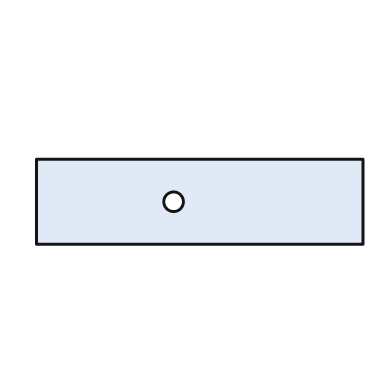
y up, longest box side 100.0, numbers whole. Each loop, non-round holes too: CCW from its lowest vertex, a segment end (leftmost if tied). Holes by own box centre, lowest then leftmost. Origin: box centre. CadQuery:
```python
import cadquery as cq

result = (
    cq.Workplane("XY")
    .moveTo(-50.0, -13.0)
    .lineTo(50.0, -13.0)
    .lineTo(50.0, 13.0)
    .lineTo(-50.0, 13.0)
    .close()
    .moveTo(-8.0, 0.0)
    .circle(3.0)
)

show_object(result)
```